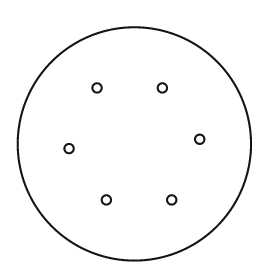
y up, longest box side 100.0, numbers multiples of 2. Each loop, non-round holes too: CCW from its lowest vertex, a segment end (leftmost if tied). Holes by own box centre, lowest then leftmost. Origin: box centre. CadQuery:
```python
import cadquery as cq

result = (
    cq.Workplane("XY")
    .moveTo(0.0, 0.0)
    .circle(50.0)
    .moveTo(-12.0, -24.0)
    .circle(2.0)
    .moveTo(16.0, -24.0)
    .circle(2.0)
    .moveTo(-28.0, -2.0)
    .circle(2.0)
    .moveTo(28.0, 2.0)
    .circle(2.0)
    .moveTo(-16.0, 24.0)
    .circle(2.0)
    .moveTo(12.0, 24.0)
    .circle(2.0)
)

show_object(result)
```